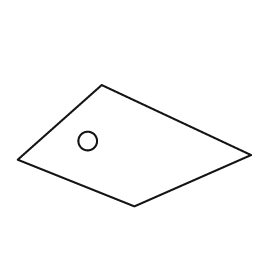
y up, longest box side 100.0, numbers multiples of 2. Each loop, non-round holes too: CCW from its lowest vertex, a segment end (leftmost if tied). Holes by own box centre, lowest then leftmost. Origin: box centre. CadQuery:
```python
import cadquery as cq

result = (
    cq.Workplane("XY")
    .moveTo(0.0, -26.0)
    .lineTo(50.0, -4.0)
    .lineTo(-14.0, 26.0)
    .lineTo(-50.0, -6.0)
    .close()
    .moveTo(-20.0, 2.0)
    .circle(4.0)
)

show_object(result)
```